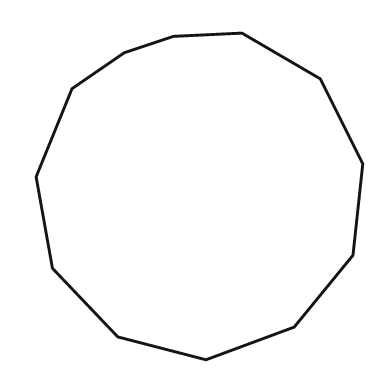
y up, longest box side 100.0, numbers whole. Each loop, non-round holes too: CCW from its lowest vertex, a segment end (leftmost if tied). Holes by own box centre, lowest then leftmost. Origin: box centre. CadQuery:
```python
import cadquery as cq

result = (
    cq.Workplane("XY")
    .moveTo(2.0, -50.0)
    .lineTo(29.0, -40.0)
    .lineTo(47.0, -18.0)
    .lineTo(50.0, 10.0)
    .lineTo(37.0, 36.0)
    .lineTo(13.0, 50.0)
    .lineTo(-8.0, 49.0)
    .lineTo(-23.0, 44.0)
    .lineTo(-39.0, 33.0)
    .lineTo(-50.0, 6.0)
    .lineTo(-45.0, -22.0)
    .lineTo(-25.0, -43.0)
    .close()
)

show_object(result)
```